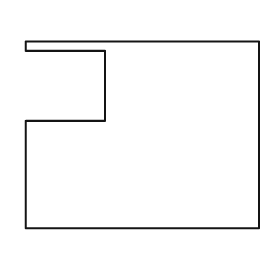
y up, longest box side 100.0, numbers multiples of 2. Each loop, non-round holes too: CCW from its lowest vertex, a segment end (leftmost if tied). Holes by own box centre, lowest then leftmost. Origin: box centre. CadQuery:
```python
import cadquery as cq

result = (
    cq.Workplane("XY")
    .moveTo(-50.0, -40.0)
    .lineTo(50.0, -40.0)
    .lineTo(50.0, 40.0)
    .lineTo(-50.0, 40.0)
    .lineTo(-50.0, 36.0)
    .lineTo(-16.0, 36.0)
    .lineTo(-16.0, 6.0)
    .lineTo(-50.0, 6.0)
    .close()
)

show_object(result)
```